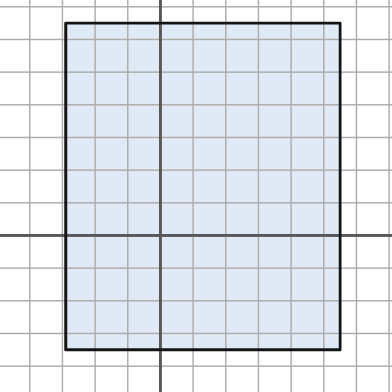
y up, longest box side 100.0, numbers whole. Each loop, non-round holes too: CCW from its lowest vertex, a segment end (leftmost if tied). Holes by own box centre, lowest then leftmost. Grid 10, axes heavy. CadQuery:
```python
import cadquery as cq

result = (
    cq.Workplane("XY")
    .moveTo(-29.0, -35.0)
    .lineTo(55.0, -35.0)
    .lineTo(55.0, 65.0)
    .lineTo(-29.0, 65.0)
    .close()
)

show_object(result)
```